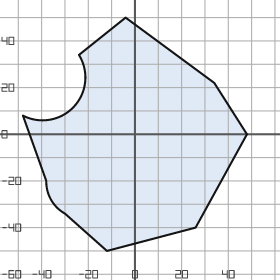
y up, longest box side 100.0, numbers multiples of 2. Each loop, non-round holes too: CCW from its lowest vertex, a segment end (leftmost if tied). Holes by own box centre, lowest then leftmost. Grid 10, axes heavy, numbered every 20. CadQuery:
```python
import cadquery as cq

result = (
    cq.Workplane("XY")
    .moveTo(-12.0, -50.0)
    .lineTo(26.0, -40.0)
    .lineTo(48.0, 0.0)
    .lineTo(34.0, 22.0)
    .lineTo(-4.0, 50.0)
    .lineTo(-24.0, 34.0)
    .threePointArc((-26.0, 12.0), (-48.0, 8.0))
    .lineTo(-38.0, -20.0)
    .threePointArc((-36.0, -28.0), (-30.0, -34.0))
    .close()
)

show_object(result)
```